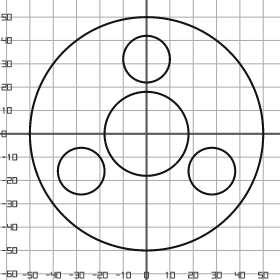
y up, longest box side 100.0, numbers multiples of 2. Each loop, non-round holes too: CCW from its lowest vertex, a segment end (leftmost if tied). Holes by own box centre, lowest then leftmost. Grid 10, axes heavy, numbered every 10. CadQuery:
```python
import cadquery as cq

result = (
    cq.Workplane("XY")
    .moveTo(0.0, 0.0)
    .circle(50.0)
    .moveTo(-28.0, -16.0)
    .circle(10.0)
    .moveTo(28.0, -16.0)
    .circle(10.0)
    .moveTo(0.0, 0.0)
    .circle(18.0)
    .moveTo(0.0, 32.0)
    .circle(10.0)
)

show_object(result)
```